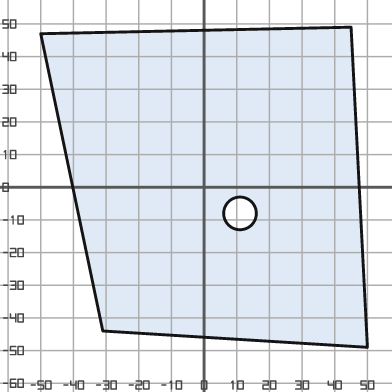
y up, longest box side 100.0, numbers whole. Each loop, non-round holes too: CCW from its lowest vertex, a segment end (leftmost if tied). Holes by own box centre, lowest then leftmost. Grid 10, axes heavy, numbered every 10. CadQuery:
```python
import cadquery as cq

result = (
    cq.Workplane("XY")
    .moveTo(50.0, -49.0)
    .lineTo(45.0, 49.0)
    .lineTo(-50.0, 47.0)
    .lineTo(-31.0, -44.0)
    .close()
    .moveTo(11.0, -8.0)
    .circle(5.0)
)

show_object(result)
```